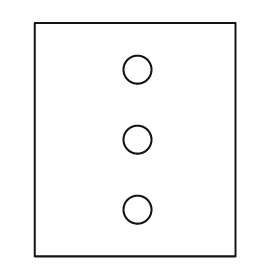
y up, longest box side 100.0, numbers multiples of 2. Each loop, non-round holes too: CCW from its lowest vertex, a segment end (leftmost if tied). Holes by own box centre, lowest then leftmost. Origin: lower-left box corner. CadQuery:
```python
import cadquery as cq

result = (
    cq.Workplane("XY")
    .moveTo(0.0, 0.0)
    .lineTo(86.0, 0.0)
    .lineTo(86.0, 100.0)
    .lineTo(0.0, 100.0)
    .close()
    .moveTo(44.0, 20.0)
    .circle(6.0)
    .moveTo(44.0, 50.0)
    .circle(6.0)
    .moveTo(44.0, 80.0)
    .circle(6.0)
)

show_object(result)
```